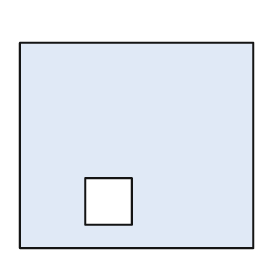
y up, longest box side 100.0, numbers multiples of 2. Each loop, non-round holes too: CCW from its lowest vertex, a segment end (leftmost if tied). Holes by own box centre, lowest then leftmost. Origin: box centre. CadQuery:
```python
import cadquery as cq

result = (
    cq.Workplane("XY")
    .moveTo(-50.0, -44.0)
    .lineTo(50.0, -44.0)
    .lineTo(50.0, 44.0)
    .lineTo(-50.0, 44.0)
    .close()
    .moveTo(-22.0, -34.0)
    .lineTo(-2.0, -34.0)
    .lineTo(-2.0, -14.0)
    .lineTo(-22.0, -14.0)
    .close()
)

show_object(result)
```